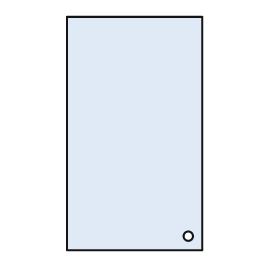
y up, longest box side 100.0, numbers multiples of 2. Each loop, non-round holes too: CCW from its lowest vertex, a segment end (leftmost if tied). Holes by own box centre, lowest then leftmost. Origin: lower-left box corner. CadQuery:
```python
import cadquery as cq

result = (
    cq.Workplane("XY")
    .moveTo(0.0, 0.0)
    .lineTo(58.0, 0.0)
    .lineTo(58.0, 100.0)
    .lineTo(0.0, 100.0)
    .close()
    .moveTo(52.0, 6.0)
    .circle(2.0)
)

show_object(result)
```